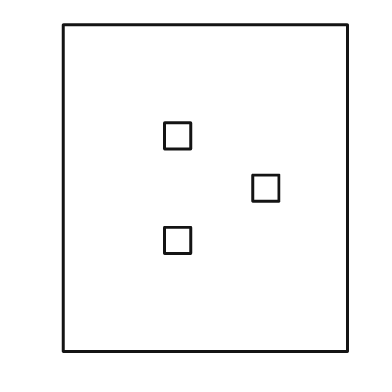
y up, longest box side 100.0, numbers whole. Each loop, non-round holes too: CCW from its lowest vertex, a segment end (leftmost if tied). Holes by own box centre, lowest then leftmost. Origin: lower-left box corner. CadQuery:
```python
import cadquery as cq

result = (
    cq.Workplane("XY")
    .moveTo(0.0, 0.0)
    .lineTo(87.0, 0.0)
    .lineTo(87.0, 100.0)
    .lineTo(0.0, 100.0)
    .close()
    .moveTo(31.0, 30.0)
    .lineTo(39.0, 30.0)
    .lineTo(39.0, 38.0)
    .lineTo(31.0, 38.0)
    .close()
    .moveTo(58.0, 46.0)
    .lineTo(66.0, 46.0)
    .lineTo(66.0, 54.0)
    .lineTo(58.0, 54.0)
    .close()
    .moveTo(31.0, 62.0)
    .lineTo(39.0, 62.0)
    .lineTo(39.0, 70.0)
    .lineTo(31.0, 70.0)
    .close()
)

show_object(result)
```